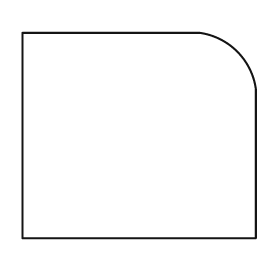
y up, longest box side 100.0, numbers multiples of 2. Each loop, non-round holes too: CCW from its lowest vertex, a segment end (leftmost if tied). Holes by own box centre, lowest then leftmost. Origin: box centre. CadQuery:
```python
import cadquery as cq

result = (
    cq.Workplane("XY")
    .moveTo(-50.0, -44.0)
    .lineTo(50.0, -44.0)
    .lineTo(50.0, 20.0)
    .threePointArc((42.0, 36.0), (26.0, 44.0))
    .lineTo(-50.0, 44.0)
    .close()
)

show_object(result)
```